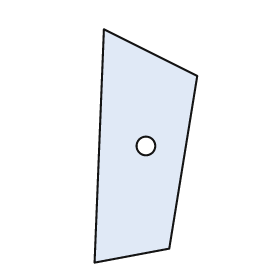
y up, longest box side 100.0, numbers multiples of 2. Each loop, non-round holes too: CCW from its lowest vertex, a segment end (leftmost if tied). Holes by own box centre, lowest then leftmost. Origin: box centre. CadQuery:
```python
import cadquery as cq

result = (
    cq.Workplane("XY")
    .moveTo(-22.0, -50.0)
    .lineTo(10.0, -44.0)
    .lineTo(22.0, 30.0)
    .lineTo(-18.0, 50.0)
    .close()
    .moveTo(0.0, 0.0)
    .circle(4.0)
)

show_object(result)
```